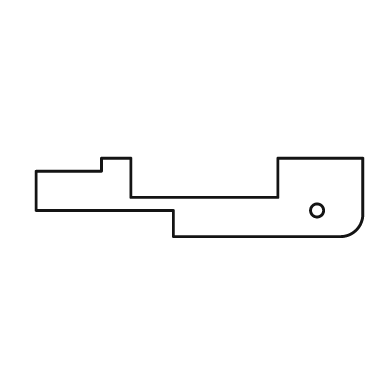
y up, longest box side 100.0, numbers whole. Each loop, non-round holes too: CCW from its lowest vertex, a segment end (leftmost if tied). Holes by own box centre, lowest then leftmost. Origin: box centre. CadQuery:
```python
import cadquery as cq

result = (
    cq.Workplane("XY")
    .moveTo(-8.0, -12.0)
    .lineTo(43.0, -12.0)
    .threePointArc((48.0, -10.0), (50.0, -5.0))
    .lineTo(50.0, 12.0)
    .lineTo(24.0, 12.0)
    .lineTo(24.0, 0.0)
    .lineTo(-21.0, 0.0)
    .lineTo(-21.0, 12.0)
    .lineTo(-30.0, 12.0)
    .lineTo(-30.0, 8.0)
    .lineTo(-50.0, 8.0)
    .lineTo(-50.0, -4.0)
    .lineTo(-8.0, -4.0)
    .close()
    .moveTo(36.0, -4.0)
    .circle(2.0)
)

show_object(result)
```